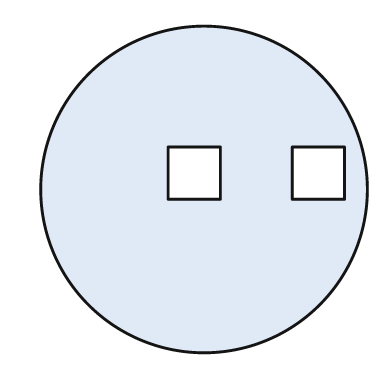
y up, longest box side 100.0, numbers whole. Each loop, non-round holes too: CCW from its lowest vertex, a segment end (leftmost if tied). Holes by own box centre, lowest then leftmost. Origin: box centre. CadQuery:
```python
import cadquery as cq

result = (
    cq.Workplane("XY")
    .moveTo(0.0, 0.0)
    .circle(50.0)
    .moveTo(-11.0, -3.0)
    .lineTo(5.0, -3.0)
    .lineTo(5.0, 13.0)
    .lineTo(-11.0, 13.0)
    .close()
    .moveTo(27.0, -3.0)
    .lineTo(43.0, -3.0)
    .lineTo(43.0, 13.0)
    .lineTo(27.0, 13.0)
    .close()
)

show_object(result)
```